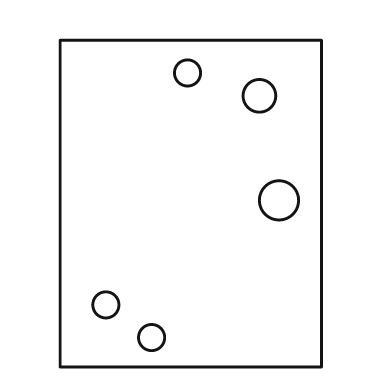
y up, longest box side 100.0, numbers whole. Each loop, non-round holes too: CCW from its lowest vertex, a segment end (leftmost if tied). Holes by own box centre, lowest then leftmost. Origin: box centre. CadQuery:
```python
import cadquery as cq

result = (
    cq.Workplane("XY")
    .moveTo(-40.0, -50.0)
    .lineTo(40.0, -50.0)
    .lineTo(40.0, 50.0)
    .lineTo(-40.0, 50.0)
    .close()
    .moveTo(-12.0, -41.0)
    .circle(4.0)
    .moveTo(-26.0, -31.0)
    .circle(4.0)
    .moveTo(27.0, 1.0)
    .circle(6.0)
    .moveTo(21.0, 33.0)
    .circle(5.0)
    .moveTo(-1.0, 40.0)
    .circle(4.0)
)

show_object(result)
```